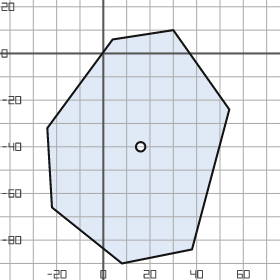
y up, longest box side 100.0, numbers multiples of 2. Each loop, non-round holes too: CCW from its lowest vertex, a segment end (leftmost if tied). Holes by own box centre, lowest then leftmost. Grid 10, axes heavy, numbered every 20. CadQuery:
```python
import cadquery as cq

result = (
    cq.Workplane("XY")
    .moveTo(8.0, -90.0)
    .lineTo(38.0, -84.0)
    .lineTo(54.0, -24.0)
    .lineTo(30.0, 10.0)
    .lineTo(4.0, 6.0)
    .lineTo(-24.0, -32.0)
    .lineTo(-22.0, -66.0)
    .close()
    .moveTo(16.0, -40.0)
    .circle(2.0)
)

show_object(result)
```